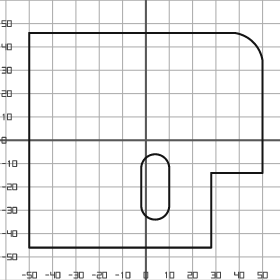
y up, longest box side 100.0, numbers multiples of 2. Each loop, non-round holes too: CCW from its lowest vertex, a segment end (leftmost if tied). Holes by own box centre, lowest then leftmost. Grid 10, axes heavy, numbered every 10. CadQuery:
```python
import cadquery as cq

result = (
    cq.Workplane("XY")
    .moveTo(-50.0, -46.0)
    .lineTo(28.0, -46.0)
    .lineTo(28.0, -14.0)
    .lineTo(50.0, -14.0)
    .lineTo(50.0, 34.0)
    .threePointArc((46.0, 42.0), (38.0, 46.0))
    .lineTo(-50.0, 46.0)
    .close()
    .moveTo(-2.0, -28.0)
    .threePointArc((4.0, -34.0), (10.0, -28.0))
    .lineTo(10.0, -12.0)
    .threePointArc((4.0, -6.0), (-2.0, -12.0))
    .close()
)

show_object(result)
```